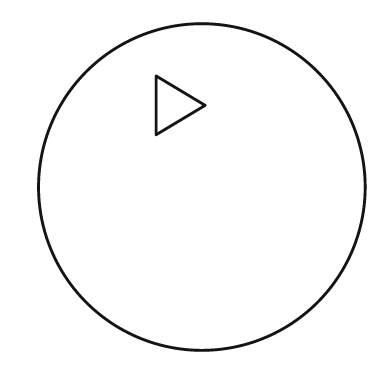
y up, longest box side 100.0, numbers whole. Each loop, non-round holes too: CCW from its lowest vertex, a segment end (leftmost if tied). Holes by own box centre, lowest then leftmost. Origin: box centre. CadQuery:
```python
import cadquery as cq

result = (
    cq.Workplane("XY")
    .moveTo(0.0, 0.0)
    .circle(50.0)
    .moveTo(-14.0, 16.0)
    .lineTo(1.0, 25.0)
    .lineTo(-14.0, 34.0)
    .close()
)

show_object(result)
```